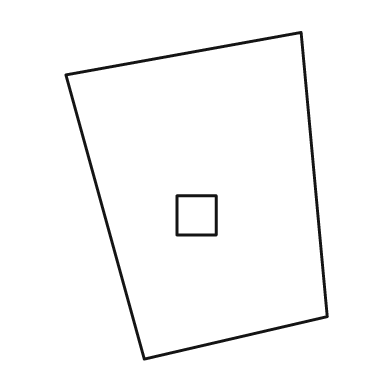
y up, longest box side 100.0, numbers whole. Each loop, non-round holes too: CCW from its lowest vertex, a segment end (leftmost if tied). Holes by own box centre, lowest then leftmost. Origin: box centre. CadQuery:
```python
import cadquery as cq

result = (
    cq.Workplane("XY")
    .moveTo(-16.0, -50.0)
    .lineTo(40.0, -37.0)
    .lineTo(32.0, 50.0)
    .lineTo(-40.0, 37.0)
    .close()
    .moveTo(-6.0, -12.0)
    .lineTo(6.0, -12.0)
    .lineTo(6.0, 0.0)
    .lineTo(-6.0, 0.0)
    .close()
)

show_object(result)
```